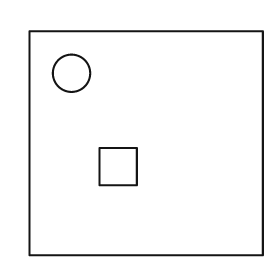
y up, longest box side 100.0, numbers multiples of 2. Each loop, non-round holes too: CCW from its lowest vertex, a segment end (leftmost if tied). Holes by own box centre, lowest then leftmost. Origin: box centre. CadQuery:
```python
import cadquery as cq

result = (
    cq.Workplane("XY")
    .moveTo(-50.0, -48.0)
    .lineTo(50.0, -48.0)
    .lineTo(50.0, 48.0)
    .lineTo(-50.0, 48.0)
    .close()
    .moveTo(-20.0, -18.0)
    .lineTo(-4.0, -18.0)
    .lineTo(-4.0, -2.0)
    .lineTo(-20.0, -2.0)
    .close()
    .moveTo(-32.0, 30.0)
    .circle(8.0)
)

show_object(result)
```